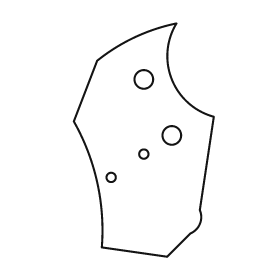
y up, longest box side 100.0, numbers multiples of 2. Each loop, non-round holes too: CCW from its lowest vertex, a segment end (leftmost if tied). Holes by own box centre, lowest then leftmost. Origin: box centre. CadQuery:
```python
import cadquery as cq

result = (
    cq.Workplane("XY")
    .moveTo(10.0, -50.0)
    .lineTo(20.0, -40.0)
    .threePointArc((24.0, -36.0), (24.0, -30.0))
    .lineTo(30.0, 10.0)
    .threePointArc((12.0, 26.0), (14.0, 50.0))
    .threePointArc((-4.0, 44.0), (-20.0, 34.0))
    .lineTo(-30.0, 8.0)
    .threePointArc((-20.0, -18.0), (-18.0, -46.0))
    .close()
    .moveTo(-14.0, -16.0)
    .circle(2.0)
    .moveTo(0.0, -6.0)
    .circle(2.0)
    .moveTo(12.0, 2.0)
    .circle(4.0)
    .moveTo(0.0, 26.0)
    .circle(4.0)
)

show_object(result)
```